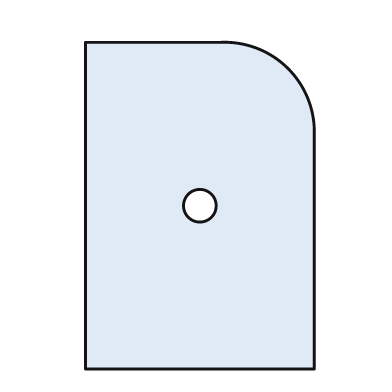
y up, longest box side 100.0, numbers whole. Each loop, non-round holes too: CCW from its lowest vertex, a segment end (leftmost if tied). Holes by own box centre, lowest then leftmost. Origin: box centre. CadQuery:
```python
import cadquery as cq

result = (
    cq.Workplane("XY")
    .moveTo(-35.0, -50.0)
    .lineTo(35.0, -50.0)
    .lineTo(35.0, 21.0)
    .threePointArc((27.0, 42.0), (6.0, 50.0))
    .lineTo(-35.0, 50.0)
    .close()
    .moveTo(0.0, 0.0)
    .circle(5.0)
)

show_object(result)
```